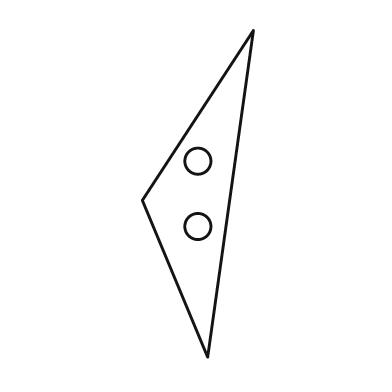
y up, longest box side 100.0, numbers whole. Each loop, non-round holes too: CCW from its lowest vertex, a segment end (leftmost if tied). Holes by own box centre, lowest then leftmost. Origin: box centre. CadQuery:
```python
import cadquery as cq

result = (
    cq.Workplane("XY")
    .moveTo(3.0, -50.0)
    .lineTo(17.0, 50.0)
    .lineTo(-17.0, -2.0)
    .close()
    .moveTo(0.0, -10.0)
    .circle(4.0)
    .moveTo(0.0, 10.0)
    .circle(4.0)
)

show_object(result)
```